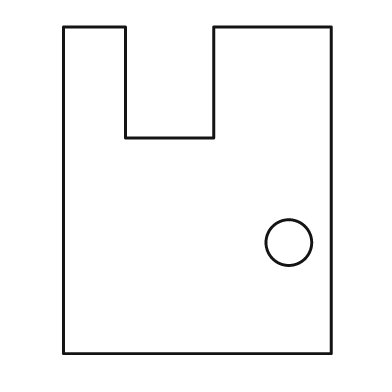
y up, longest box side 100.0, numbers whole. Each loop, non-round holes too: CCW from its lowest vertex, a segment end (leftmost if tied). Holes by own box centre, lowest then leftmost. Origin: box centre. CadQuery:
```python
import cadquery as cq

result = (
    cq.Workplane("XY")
    .moveTo(-41.0, -50.0)
    .lineTo(41.0, -50.0)
    .lineTo(41.0, 50.0)
    .lineTo(5.0, 50.0)
    .lineTo(5.0, 16.0)
    .lineTo(-22.0, 16.0)
    .lineTo(-22.0, 50.0)
    .lineTo(-41.0, 50.0)
    .close()
    .moveTo(28.0, -16.0)
    .circle(7.0)
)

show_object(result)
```